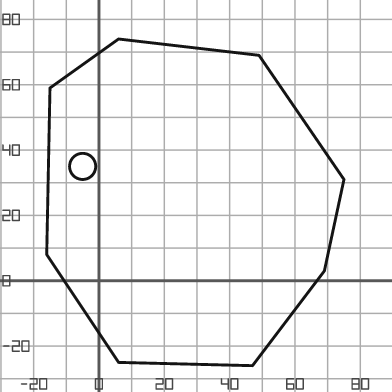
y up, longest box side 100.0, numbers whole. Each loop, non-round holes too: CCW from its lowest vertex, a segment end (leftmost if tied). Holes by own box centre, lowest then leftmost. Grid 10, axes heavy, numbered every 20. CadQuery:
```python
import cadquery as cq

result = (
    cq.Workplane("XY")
    .moveTo(47.0, -26.0)
    .lineTo(69.0, 3.0)
    .lineTo(75.0, 31.0)
    .lineTo(49.0, 69.0)
    .lineTo(6.0, 74.0)
    .lineTo(-15.0, 59.0)
    .lineTo(-16.0, 8.0)
    .lineTo(6.0, -25.0)
    .close()
    .moveTo(-5.0, 35.0)
    .circle(4.0)
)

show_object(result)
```